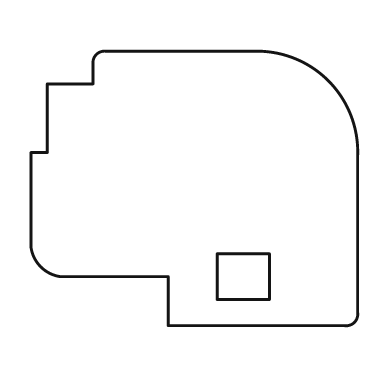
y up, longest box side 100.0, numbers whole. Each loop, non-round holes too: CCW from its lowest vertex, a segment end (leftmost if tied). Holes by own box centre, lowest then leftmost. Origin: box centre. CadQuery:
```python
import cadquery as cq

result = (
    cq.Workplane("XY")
    .moveTo(-8.0, -42.0)
    .lineTo(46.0, -42.0)
    .threePointArc((49.0, -41.0), (50.0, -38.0))
    .lineTo(50.0, 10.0)
    .threePointArc((41.0, 33.0), (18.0, 42.0))
    .lineTo(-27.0, 42.0)
    .threePointArc((-30.0, 41.0), (-31.0, 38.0))
    .lineTo(-31.0, 32.0)
    .lineTo(-45.0, 32.0)
    .lineTo(-45.0, 11.0)
    .lineTo(-50.0, 11.0)
    .lineTo(-50.0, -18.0)
    .threePointArc((-47.0, -24.0), (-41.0, -27.0))
    .lineTo(-8.0, -27.0)
    .close()
    .moveTo(7.0, -34.0)
    .lineTo(23.0, -34.0)
    .lineTo(23.0, -20.0)
    .lineTo(7.0, -20.0)
    .close()
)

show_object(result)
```